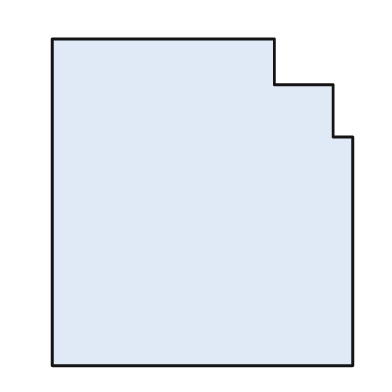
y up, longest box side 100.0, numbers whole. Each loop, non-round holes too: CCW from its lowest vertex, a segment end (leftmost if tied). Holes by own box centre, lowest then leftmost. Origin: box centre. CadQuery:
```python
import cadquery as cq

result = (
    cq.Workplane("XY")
    .moveTo(-46.0, -50.0)
    .lineTo(46.0, -50.0)
    .lineTo(46.0, 20.0)
    .lineTo(40.0, 20.0)
    .lineTo(40.0, 36.0)
    .lineTo(22.0, 36.0)
    .lineTo(22.0, 50.0)
    .lineTo(-46.0, 50.0)
    .close()
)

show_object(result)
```